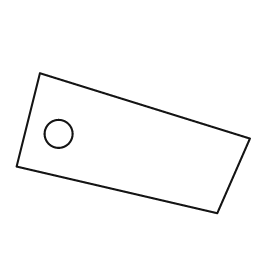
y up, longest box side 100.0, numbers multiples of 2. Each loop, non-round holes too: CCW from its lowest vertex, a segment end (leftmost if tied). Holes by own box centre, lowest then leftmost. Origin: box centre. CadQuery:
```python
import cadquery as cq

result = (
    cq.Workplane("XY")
    .moveTo(36.0, -30.0)
    .lineTo(50.0, 2.0)
    .lineTo(-40.0, 30.0)
    .lineTo(-50.0, -10.0)
    .close()
    .moveTo(-32.0, 4.0)
    .circle(6.0)
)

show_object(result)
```